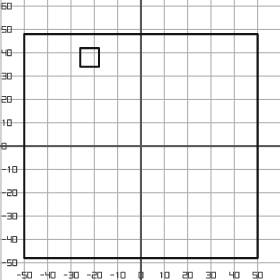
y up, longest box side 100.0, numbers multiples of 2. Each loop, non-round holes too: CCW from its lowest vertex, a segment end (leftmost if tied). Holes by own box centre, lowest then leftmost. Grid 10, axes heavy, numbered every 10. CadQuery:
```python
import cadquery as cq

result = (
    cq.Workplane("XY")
    .moveTo(-50.0, -48.0)
    .lineTo(50.0, -48.0)
    .lineTo(50.0, 48.0)
    .lineTo(-50.0, 48.0)
    .close()
    .moveTo(-26.0, 34.0)
    .lineTo(-18.0, 34.0)
    .lineTo(-18.0, 42.0)
    .lineTo(-26.0, 42.0)
    .close()
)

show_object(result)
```